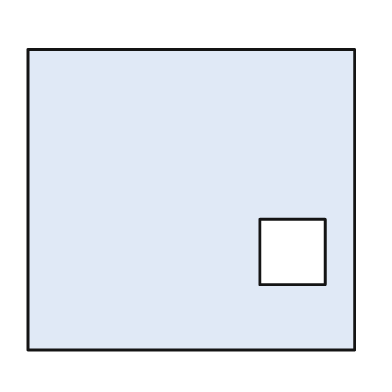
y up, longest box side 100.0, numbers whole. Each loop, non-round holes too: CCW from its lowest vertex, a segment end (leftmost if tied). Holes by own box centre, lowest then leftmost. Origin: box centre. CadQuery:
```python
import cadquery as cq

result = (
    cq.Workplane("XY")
    .moveTo(-50.0, -46.0)
    .lineTo(50.0, -46.0)
    .lineTo(50.0, 46.0)
    .lineTo(-50.0, 46.0)
    .close()
    .moveTo(21.0, -26.0)
    .lineTo(41.0, -26.0)
    .lineTo(41.0, -6.0)
    .lineTo(21.0, -6.0)
    .close()
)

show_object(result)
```